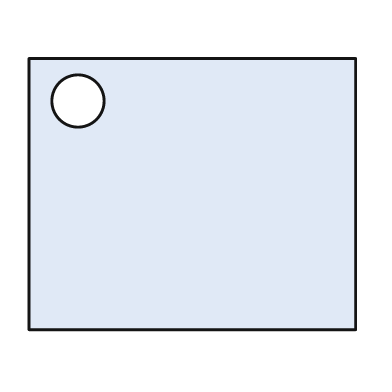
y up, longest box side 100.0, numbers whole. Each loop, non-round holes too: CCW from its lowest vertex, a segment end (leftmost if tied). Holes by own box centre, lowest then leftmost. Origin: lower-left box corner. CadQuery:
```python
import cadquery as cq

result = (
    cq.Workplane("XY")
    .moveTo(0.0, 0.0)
    .lineTo(100.0, 0.0)
    .lineTo(100.0, 83.0)
    .lineTo(0.0, 83.0)
    .close()
    .moveTo(15.0, 70.0)
    .circle(8.0)
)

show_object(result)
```